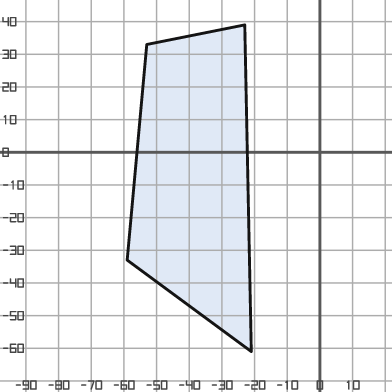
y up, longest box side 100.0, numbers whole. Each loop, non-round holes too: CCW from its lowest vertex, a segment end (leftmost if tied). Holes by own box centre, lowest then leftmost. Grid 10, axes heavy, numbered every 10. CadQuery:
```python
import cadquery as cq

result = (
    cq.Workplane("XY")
    .moveTo(-21.0, -61.0)
    .lineTo(-23.0, 39.0)
    .lineTo(-53.0, 33.0)
    .lineTo(-59.0, -33.0)
    .close()
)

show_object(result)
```